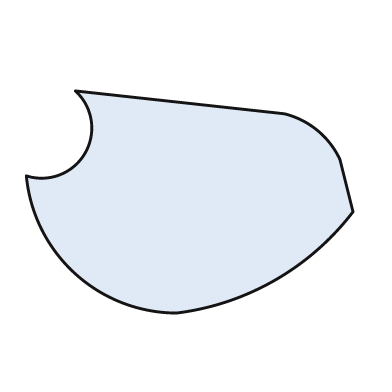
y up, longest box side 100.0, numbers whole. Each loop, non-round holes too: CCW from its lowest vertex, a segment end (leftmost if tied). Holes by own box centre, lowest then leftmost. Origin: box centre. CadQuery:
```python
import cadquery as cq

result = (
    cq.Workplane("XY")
    .moveTo(-4.0, -34.0)
    .threePointArc((26.0, -24.0), (50.0, -3.0))
    .lineTo(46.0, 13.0)
    .threePointArc((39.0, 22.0), (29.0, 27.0))
    .lineTo(-35.0, 34.0)
    .threePointArc((-32.0, 15.0), (-50.0, 8.0))
    .threePointArc((-35.0, -22.0), (-4.0, -34.0))
    .close()
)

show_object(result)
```